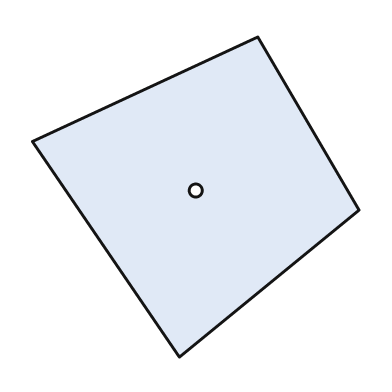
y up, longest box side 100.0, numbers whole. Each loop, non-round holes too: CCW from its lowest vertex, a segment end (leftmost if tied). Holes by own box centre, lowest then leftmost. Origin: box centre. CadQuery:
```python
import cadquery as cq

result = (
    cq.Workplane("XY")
    .moveTo(-5.0, -49.0)
    .lineTo(50.0, -4.0)
    .lineTo(19.0, 49.0)
    .lineTo(-50.0, 17.0)
    .close()
    .moveTo(0.0, 2.0)
    .circle(2.0)
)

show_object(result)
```